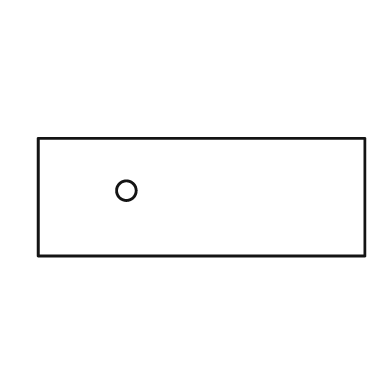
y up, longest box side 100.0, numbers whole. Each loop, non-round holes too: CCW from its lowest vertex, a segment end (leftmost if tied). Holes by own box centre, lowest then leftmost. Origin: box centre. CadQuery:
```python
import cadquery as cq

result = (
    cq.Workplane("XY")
    .moveTo(-50.0, -18.0)
    .lineTo(50.0, -18.0)
    .lineTo(50.0, 18.0)
    .lineTo(-50.0, 18.0)
    .close()
    .moveTo(-23.0, 2.0)
    .circle(3.0)
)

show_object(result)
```